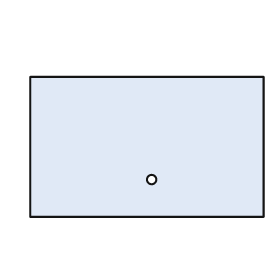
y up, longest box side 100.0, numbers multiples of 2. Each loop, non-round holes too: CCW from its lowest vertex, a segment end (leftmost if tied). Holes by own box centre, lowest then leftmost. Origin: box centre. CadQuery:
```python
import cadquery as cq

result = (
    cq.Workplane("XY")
    .moveTo(-50.0, -30.0)
    .lineTo(50.0, -30.0)
    .lineTo(50.0, 30.0)
    .lineTo(-50.0, 30.0)
    .close()
    .moveTo(2.0, -14.0)
    .circle(2.0)
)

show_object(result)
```